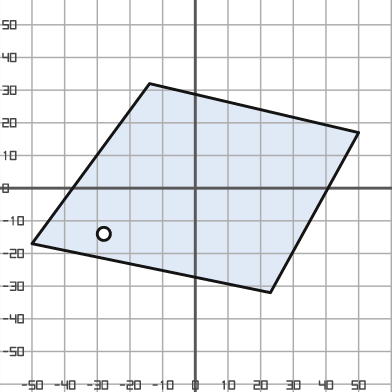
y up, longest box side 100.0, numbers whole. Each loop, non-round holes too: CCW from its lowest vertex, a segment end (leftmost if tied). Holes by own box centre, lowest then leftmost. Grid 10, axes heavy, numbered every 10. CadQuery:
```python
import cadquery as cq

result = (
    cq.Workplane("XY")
    .moveTo(23.0, -32.0)
    .lineTo(50.0, 17.0)
    .lineTo(-14.0, 32.0)
    .lineTo(-50.0, -17.0)
    .close()
    .moveTo(-28.0, -14.0)
    .circle(2.0)
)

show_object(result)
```